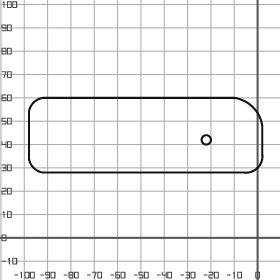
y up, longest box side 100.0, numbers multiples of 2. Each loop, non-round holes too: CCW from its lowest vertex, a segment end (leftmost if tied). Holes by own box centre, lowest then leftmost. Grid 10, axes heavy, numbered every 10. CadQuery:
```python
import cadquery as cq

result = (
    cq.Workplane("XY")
    .moveTo(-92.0, 28.0)
    .lineTo(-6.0, 28.0)
    .threePointArc((0.0, 30.0), (2.0, 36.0))
    .lineTo(2.0, 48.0)
    .threePointArc((-2.0, 56.0), (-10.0, 60.0))
    .lineTo(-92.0, 60.0)
    .threePointArc((-96.0, 58.0), (-98.0, 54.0))
    .lineTo(-98.0, 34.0)
    .threePointArc((-96.0, 30.0), (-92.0, 28.0))
    .close()
    .moveTo(-22.0, 42.0)
    .circle(2.0)
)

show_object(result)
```